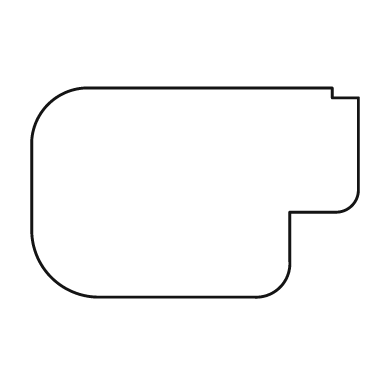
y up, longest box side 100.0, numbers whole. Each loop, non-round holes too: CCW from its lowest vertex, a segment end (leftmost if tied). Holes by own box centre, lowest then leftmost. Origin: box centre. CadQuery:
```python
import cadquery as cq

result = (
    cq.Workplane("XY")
    .moveTo(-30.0, -32.0)
    .lineTo(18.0, -32.0)
    .threePointArc((26.0, -29.0), (29.0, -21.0))
    .lineTo(29.0, -6.0)
    .lineTo(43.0, -6.0)
    .threePointArc((48.0, -4.0), (50.0, 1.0))
    .lineTo(50.0, 29.0)
    .lineTo(42.0, 29.0)
    .lineTo(42.0, 32.0)
    .lineTo(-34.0, 32.0)
    .threePointArc((-45.0, 27.0), (-50.0, 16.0))
    .lineTo(-50.0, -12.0)
    .threePointArc((-44.0, -26.0), (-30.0, -32.0))
    .close()
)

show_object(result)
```